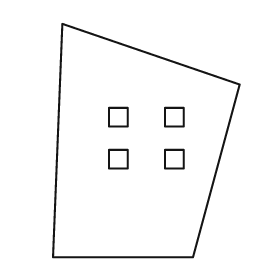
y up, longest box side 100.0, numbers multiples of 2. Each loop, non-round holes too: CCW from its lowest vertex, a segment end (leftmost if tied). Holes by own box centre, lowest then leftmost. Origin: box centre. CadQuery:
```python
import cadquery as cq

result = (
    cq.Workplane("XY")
    .moveTo(-40.0, -50.0)
    .lineTo(20.0, -50.0)
    .lineTo(40.0, 24.0)
    .lineTo(-36.0, 50.0)
    .close()
    .moveTo(-16.0, -12.0)
    .lineTo(-8.0, -12.0)
    .lineTo(-8.0, -4.0)
    .lineTo(-16.0, -4.0)
    .close()
    .moveTo(8.0, -12.0)
    .lineTo(16.0, -12.0)
    .lineTo(16.0, -4.0)
    .lineTo(8.0, -4.0)
    .close()
    .moveTo(-16.0, 6.0)
    .lineTo(-8.0, 6.0)
    .lineTo(-8.0, 14.0)
    .lineTo(-16.0, 14.0)
    .close()
    .moveTo(8.0, 6.0)
    .lineTo(16.0, 6.0)
    .lineTo(16.0, 14.0)
    .lineTo(8.0, 14.0)
    .close()
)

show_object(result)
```